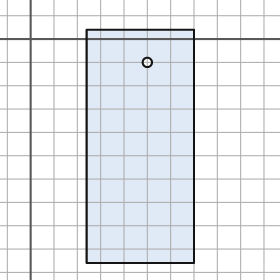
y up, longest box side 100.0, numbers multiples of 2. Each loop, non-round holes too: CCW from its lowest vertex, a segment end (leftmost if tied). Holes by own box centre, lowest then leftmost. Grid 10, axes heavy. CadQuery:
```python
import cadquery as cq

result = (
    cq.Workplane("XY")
    .moveTo(24.0, -96.0)
    .lineTo(70.0, -96.0)
    .lineTo(70.0, 4.0)
    .lineTo(24.0, 4.0)
    .close()
    .moveTo(50.0, -10.0)
    .circle(2.0)
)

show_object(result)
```